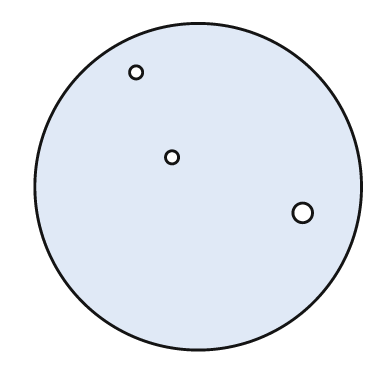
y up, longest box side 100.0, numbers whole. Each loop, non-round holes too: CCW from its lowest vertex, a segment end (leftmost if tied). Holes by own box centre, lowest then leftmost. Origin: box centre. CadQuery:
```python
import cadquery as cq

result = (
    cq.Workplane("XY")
    .moveTo(0.0, 0.0)
    .circle(50.0)
    .moveTo(32.0, -8.0)
    .circle(3.0)
    .moveTo(-8.0, 9.0)
    .circle(2.0)
    .moveTo(-19.0, 35.0)
    .circle(2.0)
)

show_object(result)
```